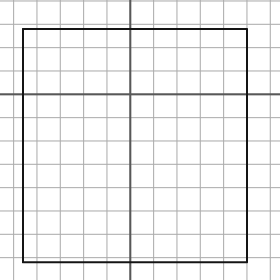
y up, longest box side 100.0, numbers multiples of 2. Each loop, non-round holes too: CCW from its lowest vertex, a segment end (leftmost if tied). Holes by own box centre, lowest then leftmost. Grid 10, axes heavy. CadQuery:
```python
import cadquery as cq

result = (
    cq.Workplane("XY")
    .moveTo(-46.0, -72.0)
    .lineTo(50.0, -72.0)
    .lineTo(50.0, 28.0)
    .lineTo(-46.0, 28.0)
    .close()
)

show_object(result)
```